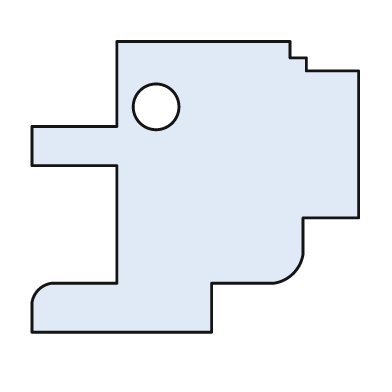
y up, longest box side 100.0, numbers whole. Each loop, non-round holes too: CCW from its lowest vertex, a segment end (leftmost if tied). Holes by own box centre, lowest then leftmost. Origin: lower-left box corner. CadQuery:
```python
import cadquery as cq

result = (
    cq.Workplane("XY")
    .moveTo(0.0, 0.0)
    .lineTo(55.0, 0.0)
    .lineTo(55.0, 15.0)
    .lineTo(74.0, 15.0)
    .threePointArc((80.0, 18.0), (83.0, 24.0))
    .lineTo(83.0, 35.0)
    .lineTo(100.0, 35.0)
    .lineTo(100.0, 80.0)
    .lineTo(84.0, 80.0)
    .lineTo(84.0, 84.0)
    .lineTo(79.0, 84.0)
    .lineTo(79.0, 89.0)
    .lineTo(26.0, 89.0)
    .lineTo(26.0, 63.0)
    .lineTo(0.0, 63.0)
    .lineTo(0.0, 51.0)
    .lineTo(26.0, 51.0)
    .lineTo(26.0, 15.0)
    .lineTo(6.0, 15.0)
    .threePointArc((2.0, 13.0), (0.0, 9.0))
    .close()
    .moveTo(38.0, 69.0)
    .circle(7.0)
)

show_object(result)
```